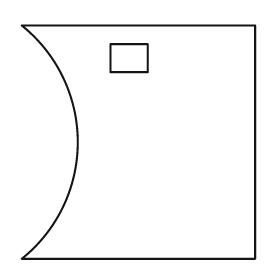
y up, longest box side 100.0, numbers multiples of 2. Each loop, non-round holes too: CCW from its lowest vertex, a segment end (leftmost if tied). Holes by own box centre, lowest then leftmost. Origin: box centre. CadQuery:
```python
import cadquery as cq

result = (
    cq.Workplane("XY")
    .moveTo(-50.0, -50.0)
    .lineTo(50.0, -50.0)
    .lineTo(50.0, 50.0)
    .lineTo(-50.0, 50.0)
    .threePointArc((-26.0, 0.0), (-50.0, -50.0))
    .close()
    .moveTo(-12.0, 30.0)
    .lineTo(4.0, 30.0)
    .lineTo(4.0, 42.0)
    .lineTo(-12.0, 42.0)
    .close()
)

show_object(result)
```